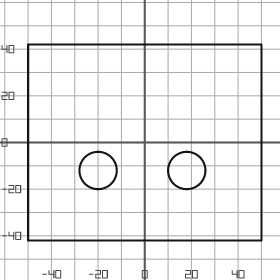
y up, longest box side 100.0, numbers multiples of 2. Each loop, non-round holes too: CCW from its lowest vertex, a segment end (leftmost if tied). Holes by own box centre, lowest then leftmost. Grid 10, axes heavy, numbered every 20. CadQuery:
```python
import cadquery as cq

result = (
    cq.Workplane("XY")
    .moveTo(-50.0, -42.0)
    .lineTo(50.0, -42.0)
    .lineTo(50.0, 42.0)
    .lineTo(-50.0, 42.0)
    .close()
    .moveTo(-20.0, -12.0)
    .circle(8.0)
    .moveTo(18.0, -12.0)
    .circle(8.0)
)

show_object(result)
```